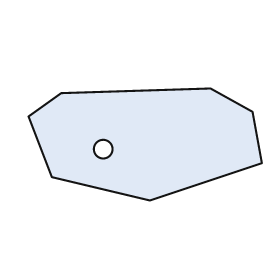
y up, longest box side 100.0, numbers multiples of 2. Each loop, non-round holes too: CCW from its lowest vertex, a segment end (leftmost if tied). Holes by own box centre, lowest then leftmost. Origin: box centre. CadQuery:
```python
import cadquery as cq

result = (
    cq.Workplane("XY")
    .moveTo(2.0, -24.0)
    .lineTo(50.0, -8.0)
    .lineTo(46.0, 14.0)
    .lineTo(28.0, 24.0)
    .lineTo(-36.0, 22.0)
    .lineTo(-50.0, 12.0)
    .lineTo(-40.0, -14.0)
    .close()
    .moveTo(-18.0, -2.0)
    .circle(4.0)
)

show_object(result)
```